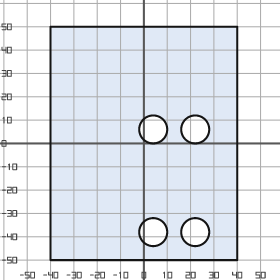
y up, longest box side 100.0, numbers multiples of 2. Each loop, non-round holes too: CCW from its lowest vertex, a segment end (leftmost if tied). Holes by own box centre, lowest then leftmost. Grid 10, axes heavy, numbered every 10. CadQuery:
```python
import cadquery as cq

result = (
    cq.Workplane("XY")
    .moveTo(-40.0, -50.0)
    .lineTo(40.0, -50.0)
    .lineTo(40.0, 50.0)
    .lineTo(-40.0, 50.0)
    .close()
    .moveTo(4.0, -38.0)
    .circle(6.0)
    .moveTo(22.0, -38.0)
    .circle(6.0)
    .moveTo(4.0, 6.0)
    .circle(6.0)
    .moveTo(22.0, 6.0)
    .circle(6.0)
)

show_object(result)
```